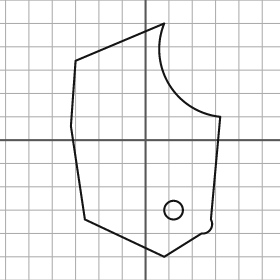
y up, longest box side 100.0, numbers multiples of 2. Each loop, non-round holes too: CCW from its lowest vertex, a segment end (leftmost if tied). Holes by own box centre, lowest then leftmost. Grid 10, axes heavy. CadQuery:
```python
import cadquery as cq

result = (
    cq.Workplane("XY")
    .moveTo(8.0, -50.0)
    .lineTo(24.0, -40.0)
    .threePointArc((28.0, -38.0), (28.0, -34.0))
    .lineTo(32.0, 10.0)
    .threePointArc((10.0, 24.0), (8.0, 50.0))
    .lineTo(-30.0, 34.0)
    .lineTo(-32.0, 6.0)
    .lineTo(-26.0, -34.0)
    .close()
    .moveTo(12.0, -30.0)
    .circle(4.0)
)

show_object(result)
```